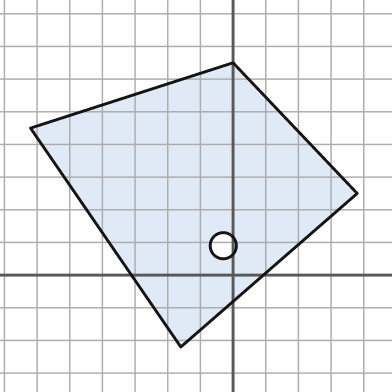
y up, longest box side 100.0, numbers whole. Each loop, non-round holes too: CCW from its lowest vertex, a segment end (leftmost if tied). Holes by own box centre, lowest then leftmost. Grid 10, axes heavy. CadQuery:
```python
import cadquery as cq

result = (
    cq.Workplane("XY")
    .moveTo(-16.0, -22.0)
    .lineTo(38.0, 25.0)
    .lineTo(0.0, 65.0)
    .lineTo(-62.0, 45.0)
    .close()
    .moveTo(-3.0, 9.0)
    .circle(4.0)
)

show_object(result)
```